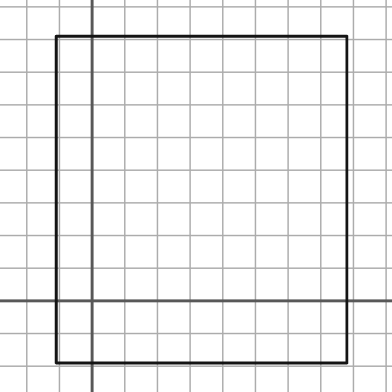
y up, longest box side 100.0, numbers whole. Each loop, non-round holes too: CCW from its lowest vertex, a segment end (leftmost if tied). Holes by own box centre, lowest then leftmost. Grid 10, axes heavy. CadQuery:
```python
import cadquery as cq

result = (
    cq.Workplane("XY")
    .moveTo(-11.0, -19.0)
    .lineTo(78.0, -19.0)
    .lineTo(78.0, 81.0)
    .lineTo(-11.0, 81.0)
    .close()
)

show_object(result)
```